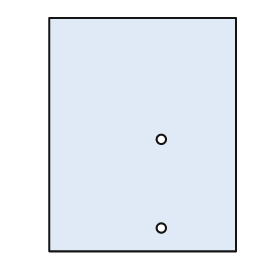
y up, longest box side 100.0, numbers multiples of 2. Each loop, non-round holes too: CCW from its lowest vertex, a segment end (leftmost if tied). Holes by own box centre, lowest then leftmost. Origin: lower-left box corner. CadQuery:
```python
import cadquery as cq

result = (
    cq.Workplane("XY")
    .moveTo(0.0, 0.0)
    .lineTo(80.0, 0.0)
    .lineTo(80.0, 100.0)
    .lineTo(0.0, 100.0)
    .close()
    .moveTo(48.0, 10.0)
    .circle(2.0)
    .moveTo(48.0, 48.0)
    .circle(2.0)
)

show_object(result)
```